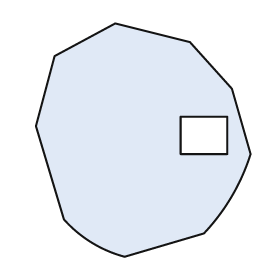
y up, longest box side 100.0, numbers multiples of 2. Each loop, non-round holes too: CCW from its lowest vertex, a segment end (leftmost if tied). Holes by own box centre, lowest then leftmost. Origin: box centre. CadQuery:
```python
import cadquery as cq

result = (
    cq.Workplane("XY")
    .moveTo(-8.0, -50.0)
    .lineTo(26.0, -40.0)
    .threePointArc((38.0, -24.0), (46.0, -6.0))
    .lineTo(38.0, 22.0)
    .lineTo(20.0, 42.0)
    .lineTo(-12.0, 50.0)
    .lineTo(-38.0, 36.0)
    .lineTo(-46.0, 6.0)
    .lineTo(-34.0, -34.0)
    .threePointArc((-22.0, -44.0), (-8.0, -50.0))
    .close()
    .moveTo(16.0, -6.0)
    .lineTo(36.0, -6.0)
    .lineTo(36.0, 10.0)
    .lineTo(16.0, 10.0)
    .close()
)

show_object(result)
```